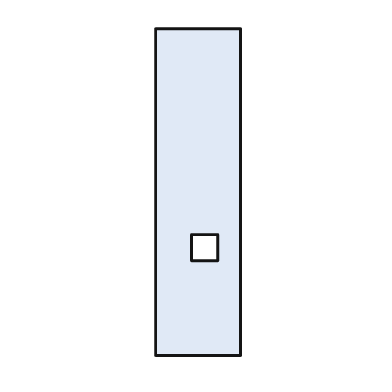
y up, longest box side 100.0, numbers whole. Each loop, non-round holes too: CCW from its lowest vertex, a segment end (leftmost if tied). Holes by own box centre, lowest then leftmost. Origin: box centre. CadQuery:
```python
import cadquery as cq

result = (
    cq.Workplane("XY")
    .moveTo(-13.0, -50.0)
    .lineTo(13.0, -50.0)
    .lineTo(13.0, 50.0)
    .lineTo(-13.0, 50.0)
    .close()
    .moveTo(-2.0, -21.0)
    .lineTo(6.0, -21.0)
    .lineTo(6.0, -13.0)
    .lineTo(-2.0, -13.0)
    .close()
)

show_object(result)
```